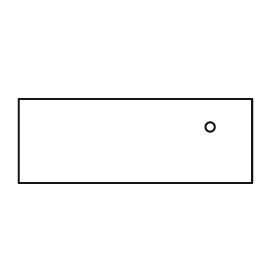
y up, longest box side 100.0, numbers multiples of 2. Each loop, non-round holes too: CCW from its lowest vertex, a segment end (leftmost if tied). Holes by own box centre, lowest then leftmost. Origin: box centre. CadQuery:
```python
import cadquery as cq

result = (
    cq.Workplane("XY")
    .moveTo(-50.0, -18.0)
    .lineTo(50.0, -18.0)
    .lineTo(50.0, 18.0)
    .lineTo(-50.0, 18.0)
    .close()
    .moveTo(32.0, 6.0)
    .circle(2.0)
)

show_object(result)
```